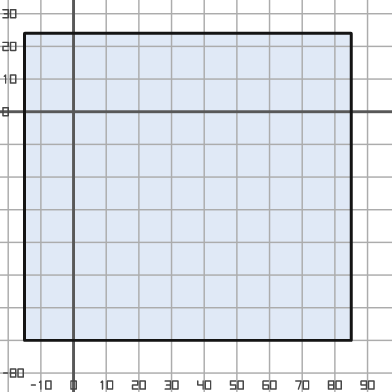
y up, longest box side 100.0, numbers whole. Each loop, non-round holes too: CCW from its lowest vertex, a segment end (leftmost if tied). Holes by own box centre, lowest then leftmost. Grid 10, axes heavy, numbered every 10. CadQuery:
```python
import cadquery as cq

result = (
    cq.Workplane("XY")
    .moveTo(-15.0, -70.0)
    .lineTo(85.0, -70.0)
    .lineTo(85.0, 24.0)
    .lineTo(-15.0, 24.0)
    .close()
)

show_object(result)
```